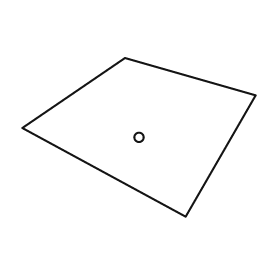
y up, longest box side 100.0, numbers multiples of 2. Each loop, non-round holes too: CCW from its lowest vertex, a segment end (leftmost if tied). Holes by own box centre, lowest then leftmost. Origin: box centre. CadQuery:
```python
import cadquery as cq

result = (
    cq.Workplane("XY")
    .moveTo(20.0, -34.0)
    .lineTo(50.0, 18.0)
    .lineTo(-6.0, 34.0)
    .lineTo(-50.0, 4.0)
    .close()
    .moveTo(0.0, 0.0)
    .circle(2.0)
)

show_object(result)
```